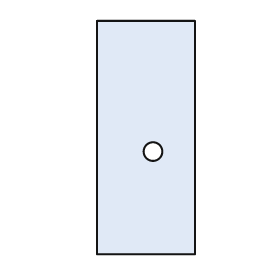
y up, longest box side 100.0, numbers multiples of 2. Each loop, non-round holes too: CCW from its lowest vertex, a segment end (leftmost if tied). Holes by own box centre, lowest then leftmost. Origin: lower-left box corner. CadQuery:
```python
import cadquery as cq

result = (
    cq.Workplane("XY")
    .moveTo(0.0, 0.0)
    .lineTo(42.0, 0.0)
    .lineTo(42.0, 100.0)
    .lineTo(0.0, 100.0)
    .close()
    .moveTo(24.0, 44.0)
    .circle(4.0)
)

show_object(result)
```